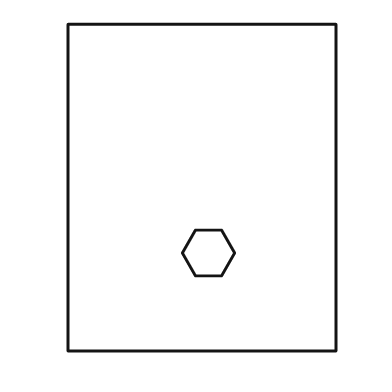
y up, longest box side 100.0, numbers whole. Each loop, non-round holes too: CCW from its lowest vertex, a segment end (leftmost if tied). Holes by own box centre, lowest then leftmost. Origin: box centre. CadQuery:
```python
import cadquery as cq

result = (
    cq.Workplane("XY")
    .moveTo(-41.0, -50.0)
    .lineTo(41.0, -50.0)
    .lineTo(41.0, 50.0)
    .lineTo(-41.0, 50.0)
    .close()
    .moveTo(-2.0, -27.0)
    .lineTo(6.0, -27.0)
    .lineTo(10.0, -20.0)
    .lineTo(6.0, -13.0)
    .lineTo(-2.0, -13.0)
    .lineTo(-6.0, -20.0)
    .close()
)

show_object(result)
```